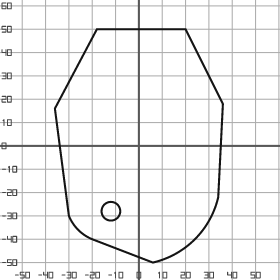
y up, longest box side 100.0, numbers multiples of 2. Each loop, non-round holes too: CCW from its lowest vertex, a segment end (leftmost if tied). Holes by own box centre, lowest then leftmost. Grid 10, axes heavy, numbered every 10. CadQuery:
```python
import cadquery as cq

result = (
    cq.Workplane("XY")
    .moveTo(6.0, -50.0)
    .threePointArc((24.0, -40.0), (34.0, -22.0))
    .lineTo(36.0, 18.0)
    .lineTo(20.0, 50.0)
    .lineTo(-18.0, 50.0)
    .lineTo(-36.0, 16.0)
    .lineTo(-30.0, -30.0)
    .threePointArc((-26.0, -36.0), (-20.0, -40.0))
    .close()
    .moveTo(-12.0, -28.0)
    .circle(4.0)
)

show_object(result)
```